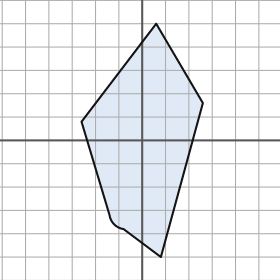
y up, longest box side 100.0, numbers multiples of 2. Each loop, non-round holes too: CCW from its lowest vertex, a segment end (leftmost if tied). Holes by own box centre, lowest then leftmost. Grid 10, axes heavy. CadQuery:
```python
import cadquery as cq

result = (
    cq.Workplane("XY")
    .moveTo(8.0, -50.0)
    .lineTo(26.0, 16.0)
    .lineTo(6.0, 50.0)
    .lineTo(-26.0, 8.0)
    .lineTo(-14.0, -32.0)
    .threePointArc((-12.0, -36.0), (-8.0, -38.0))
    .close()
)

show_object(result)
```